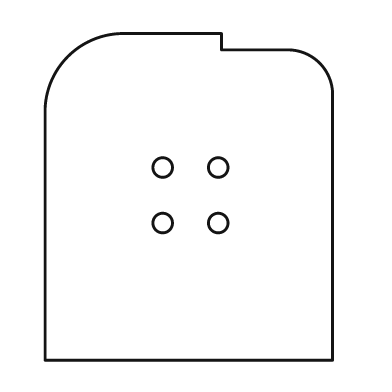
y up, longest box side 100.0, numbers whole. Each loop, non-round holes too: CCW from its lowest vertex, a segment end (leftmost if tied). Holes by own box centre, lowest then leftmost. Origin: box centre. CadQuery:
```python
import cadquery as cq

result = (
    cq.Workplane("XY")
    .moveTo(-44.0, -50.0)
    .lineTo(44.0, -50.0)
    .lineTo(44.0, 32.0)
    .threePointArc((40.0, 41.0), (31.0, 45.0))
    .lineTo(10.0, 45.0)
    .lineTo(10.0, 50.0)
    .lineTo(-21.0, 50.0)
    .threePointArc((-37.0, 43.0), (-44.0, 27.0))
    .close()
    .moveTo(-8.0, -8.0)
    .circle(3.0)
    .moveTo(9.0, -8.0)
    .circle(3.0)
    .moveTo(-8.0, 9.0)
    .circle(3.0)
    .moveTo(9.0, 9.0)
    .circle(3.0)
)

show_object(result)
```